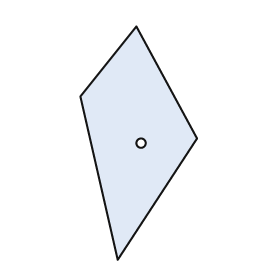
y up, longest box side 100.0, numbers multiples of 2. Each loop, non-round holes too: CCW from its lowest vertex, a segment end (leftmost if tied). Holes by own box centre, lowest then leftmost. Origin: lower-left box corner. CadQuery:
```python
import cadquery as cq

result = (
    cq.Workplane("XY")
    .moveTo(16.0, 0.0)
    .lineTo(50.0, 52.0)
    .lineTo(24.0, 100.0)
    .lineTo(0.0, 70.0)
    .close()
    .moveTo(26.0, 50.0)
    .circle(2.0)
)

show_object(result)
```